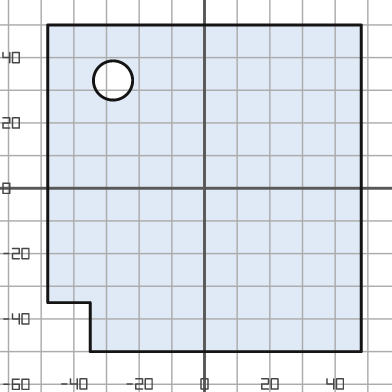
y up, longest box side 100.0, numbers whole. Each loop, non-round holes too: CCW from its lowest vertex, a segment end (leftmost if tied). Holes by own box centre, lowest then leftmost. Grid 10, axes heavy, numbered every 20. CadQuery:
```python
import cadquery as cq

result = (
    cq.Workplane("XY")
    .moveTo(-35.0, -50.0)
    .lineTo(48.0, -50.0)
    .lineTo(48.0, 50.0)
    .lineTo(-48.0, 50.0)
    .lineTo(-48.0, -35.0)
    .lineTo(-35.0, -35.0)
    .close()
    .moveTo(-28.0, 33.0)
    .circle(6.0)
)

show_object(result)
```